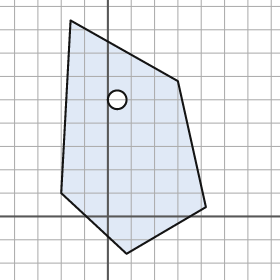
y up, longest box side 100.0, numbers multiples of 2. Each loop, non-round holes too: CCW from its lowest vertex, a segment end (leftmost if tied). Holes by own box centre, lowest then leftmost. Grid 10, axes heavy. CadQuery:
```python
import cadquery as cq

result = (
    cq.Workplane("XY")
    .moveTo(8.0, -16.0)
    .lineTo(42.0, 4.0)
    .lineTo(30.0, 58.0)
    .lineTo(-16.0, 84.0)
    .lineTo(-20.0, 10.0)
    .close()
    .moveTo(4.0, 50.0)
    .circle(4.0)
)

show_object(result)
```